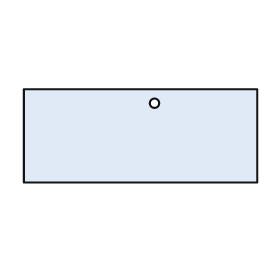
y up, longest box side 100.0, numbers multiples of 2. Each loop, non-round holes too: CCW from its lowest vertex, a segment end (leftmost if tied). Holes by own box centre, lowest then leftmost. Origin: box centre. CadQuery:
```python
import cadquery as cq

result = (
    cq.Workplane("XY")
    .moveTo(-50.0, -20.0)
    .lineTo(50.0, -20.0)
    .lineTo(50.0, 20.0)
    .lineTo(-50.0, 20.0)
    .close()
    .moveTo(6.0, 14.0)
    .circle(2.0)
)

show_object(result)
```